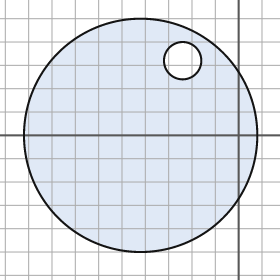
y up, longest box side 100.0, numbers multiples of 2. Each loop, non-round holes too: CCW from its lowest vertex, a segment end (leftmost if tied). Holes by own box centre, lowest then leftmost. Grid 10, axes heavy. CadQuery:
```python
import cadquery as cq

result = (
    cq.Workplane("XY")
    .moveTo(-42.0, 0.0)
    .circle(50.0)
    .moveTo(-24.0, 32.0)
    .circle(8.0)
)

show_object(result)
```